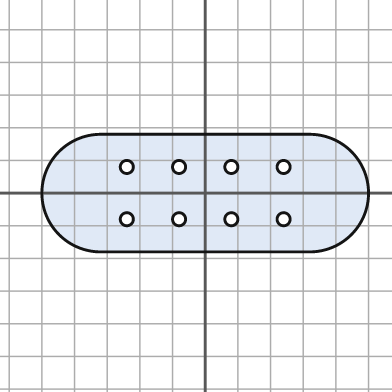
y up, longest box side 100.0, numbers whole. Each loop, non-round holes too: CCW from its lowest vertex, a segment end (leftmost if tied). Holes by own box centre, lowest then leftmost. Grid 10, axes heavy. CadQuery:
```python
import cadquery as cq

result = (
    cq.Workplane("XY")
    .moveTo(-32.0, -18.0)
    .lineTo(32.0, -18.0)
    .threePointArc((50.0, 0.0), (32.0, 18.0))
    .lineTo(-32.0, 18.0)
    .threePointArc((-50.0, 0.0), (-32.0, -18.0))
    .close()
    .moveTo(-24.0, -8.0)
    .circle(2.0)
    .moveTo(-8.0, -8.0)
    .circle(2.0)
    .moveTo(8.0, -8.0)
    .circle(2.0)
    .moveTo(24.0, -8.0)
    .circle(2.0)
    .moveTo(-24.0, 8.0)
    .circle(2.0)
    .moveTo(-8.0, 8.0)
    .circle(2.0)
    .moveTo(8.0, 8.0)
    .circle(2.0)
    .moveTo(24.0, 8.0)
    .circle(2.0)
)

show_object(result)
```